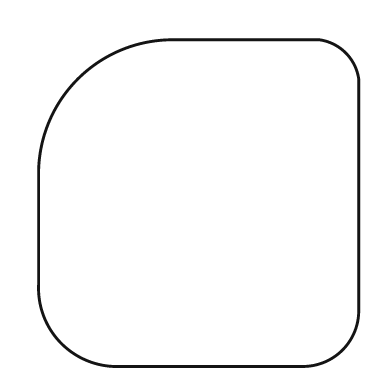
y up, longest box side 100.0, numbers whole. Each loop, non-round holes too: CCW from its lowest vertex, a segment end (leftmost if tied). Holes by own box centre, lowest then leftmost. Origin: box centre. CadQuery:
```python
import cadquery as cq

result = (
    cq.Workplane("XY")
    .moveTo(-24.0, -50.0)
    .lineTo(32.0, -50.0)
    .threePointArc((44.0, -45.0), (49.0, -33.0))
    .lineTo(49.0, 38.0)
    .threePointArc((45.0, 46.0), (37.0, 50.0))
    .lineTo(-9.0, 50.0)
    .threePointArc((-37.0, 38.0), (-49.0, 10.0))
    .lineTo(-49.0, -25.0)
    .threePointArc((-42.0, -43.0), (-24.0, -50.0))
    .close()
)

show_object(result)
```